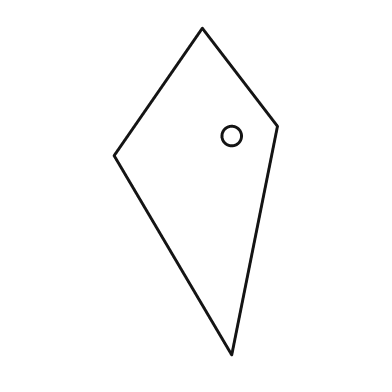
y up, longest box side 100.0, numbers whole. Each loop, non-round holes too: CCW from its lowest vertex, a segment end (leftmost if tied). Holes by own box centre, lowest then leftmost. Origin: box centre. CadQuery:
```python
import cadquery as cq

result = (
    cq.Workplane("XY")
    .moveTo(11.0, -50.0)
    .lineTo(25.0, 20.0)
    .lineTo(2.0, 50.0)
    .lineTo(-25.0, 11.0)
    .close()
    .moveTo(11.0, 17.0)
    .circle(3.0)
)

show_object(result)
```